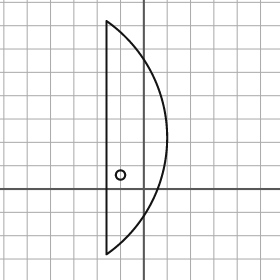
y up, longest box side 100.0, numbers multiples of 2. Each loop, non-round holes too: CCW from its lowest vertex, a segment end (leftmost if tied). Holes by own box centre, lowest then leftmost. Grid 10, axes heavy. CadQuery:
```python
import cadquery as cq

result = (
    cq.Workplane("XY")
    .moveTo(-16.0, -28.0)
    .threePointArc((10.0, 22.0), (-16.0, 72.0))
    .close()
    .moveTo(-10.0, 6.0)
    .circle(2.0)
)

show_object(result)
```